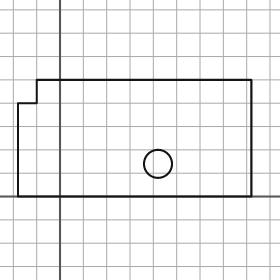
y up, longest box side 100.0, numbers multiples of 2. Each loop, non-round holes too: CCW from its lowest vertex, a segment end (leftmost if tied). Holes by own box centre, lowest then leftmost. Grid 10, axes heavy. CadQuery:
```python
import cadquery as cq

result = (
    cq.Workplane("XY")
    .moveTo(-18.0, 0.0)
    .lineTo(82.0, 0.0)
    .lineTo(82.0, 50.0)
    .lineTo(-10.0, 50.0)
    .lineTo(-10.0, 40.0)
    .lineTo(-18.0, 40.0)
    .close()
    .moveTo(42.0, 14.0)
    .circle(6.0)
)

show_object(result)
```